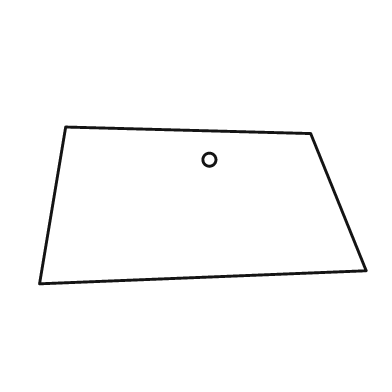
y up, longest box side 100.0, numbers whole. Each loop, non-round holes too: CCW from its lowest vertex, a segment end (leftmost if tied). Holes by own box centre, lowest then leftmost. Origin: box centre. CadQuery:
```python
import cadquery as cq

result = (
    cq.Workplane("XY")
    .moveTo(-50.0, -24.0)
    .lineTo(50.0, -20.0)
    .lineTo(33.0, 22.0)
    .lineTo(-42.0, 24.0)
    .close()
    .moveTo(2.0, 14.0)
    .circle(2.0)
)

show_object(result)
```